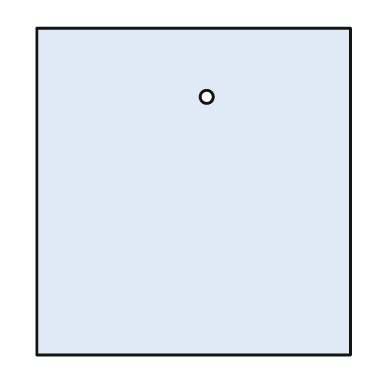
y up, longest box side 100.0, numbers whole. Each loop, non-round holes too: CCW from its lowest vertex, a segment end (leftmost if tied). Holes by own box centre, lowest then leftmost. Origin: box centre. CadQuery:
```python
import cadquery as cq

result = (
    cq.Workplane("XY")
    .moveTo(-48.0, -50.0)
    .lineTo(48.0, -50.0)
    .lineTo(48.0, 50.0)
    .lineTo(-48.0, 50.0)
    .close()
    .moveTo(4.0, 29.0)
    .circle(2.0)
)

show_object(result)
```